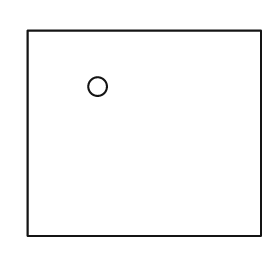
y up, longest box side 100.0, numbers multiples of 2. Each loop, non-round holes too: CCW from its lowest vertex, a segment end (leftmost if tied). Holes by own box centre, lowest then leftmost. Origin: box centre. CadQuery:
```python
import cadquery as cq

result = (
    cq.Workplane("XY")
    .moveTo(-50.0, -44.0)
    .lineTo(50.0, -44.0)
    .lineTo(50.0, 44.0)
    .lineTo(-50.0, 44.0)
    .close()
    .moveTo(-20.0, 20.0)
    .circle(4.0)
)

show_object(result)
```